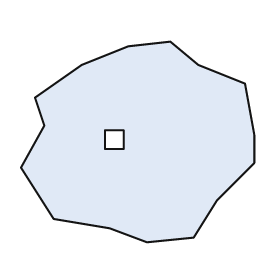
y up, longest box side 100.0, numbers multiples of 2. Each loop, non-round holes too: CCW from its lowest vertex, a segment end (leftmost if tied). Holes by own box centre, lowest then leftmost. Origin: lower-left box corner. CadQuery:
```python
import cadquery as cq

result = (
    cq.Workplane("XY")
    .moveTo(54.0, 0.0)
    .lineTo(74.0, 2.0)
    .lineTo(84.0, 18.0)
    .lineTo(100.0, 34.0)
    .lineTo(100.0, 46.0)
    .lineTo(96.0, 68.0)
    .lineTo(76.0, 76.0)
    .lineTo(64.0, 86.0)
    .lineTo(46.0, 84.0)
    .lineTo(26.0, 76.0)
    .lineTo(6.0, 62.0)
    .lineTo(10.0, 50.0)
    .lineTo(0.0, 32.0)
    .lineTo(14.0, 10.0)
    .lineTo(38.0, 6.0)
    .close()
    .moveTo(36.0, 40.0)
    .lineTo(44.0, 40.0)
    .lineTo(44.0, 48.0)
    .lineTo(36.0, 48.0)
    .close()
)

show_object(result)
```